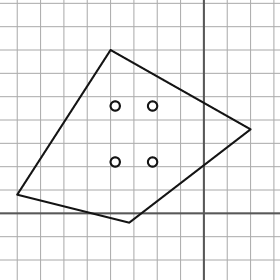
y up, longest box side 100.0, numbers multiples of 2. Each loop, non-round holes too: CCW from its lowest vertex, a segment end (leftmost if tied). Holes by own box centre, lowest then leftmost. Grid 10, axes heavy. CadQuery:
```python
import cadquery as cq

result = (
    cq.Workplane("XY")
    .moveTo(-32.0, -4.0)
    .lineTo(20.0, 36.0)
    .lineTo(-40.0, 70.0)
    .lineTo(-80.0, 8.0)
    .close()
    .moveTo(-38.0, 22.0)
    .circle(2.0)
    .moveTo(-22.0, 22.0)
    .circle(2.0)
    .moveTo(-38.0, 46.0)
    .circle(2.0)
    .moveTo(-22.0, 46.0)
    .circle(2.0)
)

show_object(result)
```